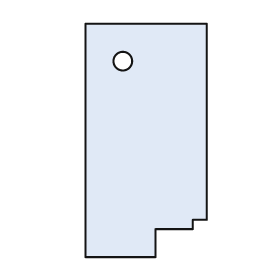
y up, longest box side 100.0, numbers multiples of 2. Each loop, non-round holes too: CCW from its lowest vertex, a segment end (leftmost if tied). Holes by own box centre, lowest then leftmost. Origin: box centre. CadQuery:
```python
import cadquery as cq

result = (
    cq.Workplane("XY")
    .moveTo(-26.0, -50.0)
    .lineTo(4.0, -50.0)
    .lineTo(4.0, -38.0)
    .lineTo(20.0, -38.0)
    .lineTo(20.0, -34.0)
    .lineTo(26.0, -34.0)
    .lineTo(26.0, 50.0)
    .lineTo(-26.0, 50.0)
    .close()
    .moveTo(-10.0, 34.0)
    .circle(4.0)
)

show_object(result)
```